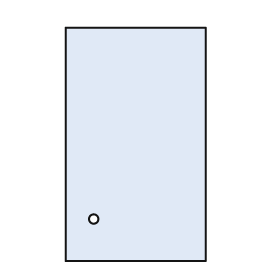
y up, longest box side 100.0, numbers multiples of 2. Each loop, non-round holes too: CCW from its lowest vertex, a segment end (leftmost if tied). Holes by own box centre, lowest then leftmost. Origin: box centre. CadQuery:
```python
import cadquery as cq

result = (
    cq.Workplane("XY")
    .moveTo(-30.0, -50.0)
    .lineTo(30.0, -50.0)
    .lineTo(30.0, 50.0)
    .lineTo(-30.0, 50.0)
    .close()
    .moveTo(-18.0, -32.0)
    .circle(2.0)
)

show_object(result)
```